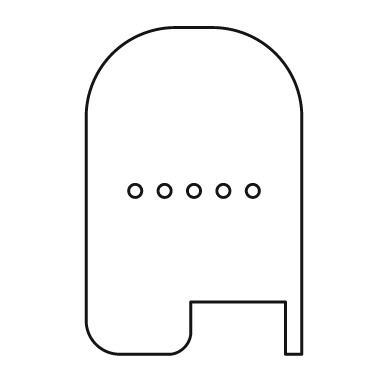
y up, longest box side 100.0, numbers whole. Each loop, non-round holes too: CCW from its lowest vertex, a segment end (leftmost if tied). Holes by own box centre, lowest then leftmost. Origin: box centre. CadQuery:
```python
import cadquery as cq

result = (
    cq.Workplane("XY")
    .moveTo(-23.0, -50.0)
    .lineTo(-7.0, -50.0)
    .threePointArc((-3.0, -48.0), (-1.0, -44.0))
    .lineTo(-1.0, -34.0)
    .lineTo(28.0, -34.0)
    .lineTo(28.0, -50.0)
    .lineTo(33.0, -50.0)
    .lineTo(33.0, 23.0)
    .threePointArc((25.0, 42.0), (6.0, 50.0))
    .lineTo(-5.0, 50.0)
    .threePointArc((-25.0, 42.0), (-33.0, 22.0))
    .lineTo(-33.0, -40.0)
    .threePointArc((-30.0, -47.0), (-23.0, -50.0))
    .close()
    .moveTo(-18.0, 0.0)
    .circle(2.0)
    .moveTo(-9.0, 0.0)
    .circle(2.0)
    .moveTo(0.0, 0.0)
    .circle(2.0)
    .moveTo(9.0, 0.0)
    .circle(2.0)
    .moveTo(18.0, 0.0)
    .circle(2.0)
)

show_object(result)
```